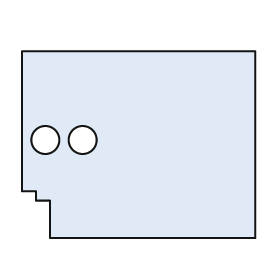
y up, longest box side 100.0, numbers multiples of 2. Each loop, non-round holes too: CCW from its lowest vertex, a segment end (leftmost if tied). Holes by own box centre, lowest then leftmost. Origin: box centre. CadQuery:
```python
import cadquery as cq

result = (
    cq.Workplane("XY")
    .moveTo(-38.0, -40.0)
    .lineTo(50.0, -40.0)
    .lineTo(50.0, 40.0)
    .lineTo(-50.0, 40.0)
    .lineTo(-50.0, -20.0)
    .lineTo(-44.0, -20.0)
    .lineTo(-44.0, -24.0)
    .lineTo(-38.0, -24.0)
    .close()
    .moveTo(-40.0, 2.0)
    .circle(6.0)
    .moveTo(-24.0, 2.0)
    .circle(6.0)
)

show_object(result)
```